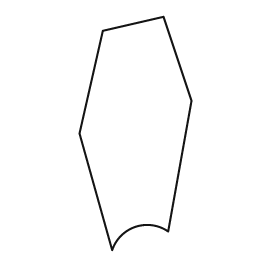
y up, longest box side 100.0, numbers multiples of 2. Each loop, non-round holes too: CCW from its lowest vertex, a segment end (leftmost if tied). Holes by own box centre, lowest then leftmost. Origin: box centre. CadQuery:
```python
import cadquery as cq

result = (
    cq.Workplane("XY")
    .moveTo(-10.0, -50.0)
    .threePointArc((0.0, -40.0), (14.0, -42.0))
    .lineTo(24.0, 14.0)
    .lineTo(12.0, 50.0)
    .lineTo(-14.0, 44.0)
    .lineTo(-24.0, 0.0)
    .close()
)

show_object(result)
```